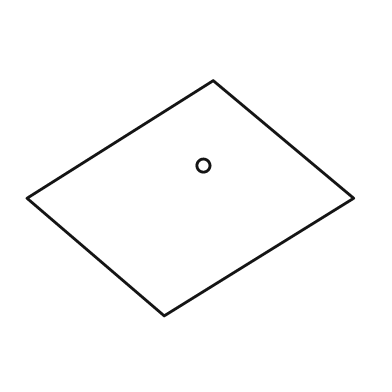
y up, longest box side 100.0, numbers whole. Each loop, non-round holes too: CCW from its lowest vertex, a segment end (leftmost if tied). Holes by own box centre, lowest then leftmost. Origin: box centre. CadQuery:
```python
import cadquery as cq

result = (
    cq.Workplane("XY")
    .moveTo(-8.0, -36.0)
    .lineTo(50.0, 0.0)
    .lineTo(7.0, 36.0)
    .lineTo(-50.0, 0.0)
    .close()
    .moveTo(4.0, 10.0)
    .circle(2.0)
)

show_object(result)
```